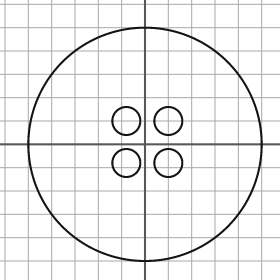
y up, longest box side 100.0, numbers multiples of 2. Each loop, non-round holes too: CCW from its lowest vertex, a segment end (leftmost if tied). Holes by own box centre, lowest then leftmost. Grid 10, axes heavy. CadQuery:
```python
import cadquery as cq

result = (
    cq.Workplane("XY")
    .moveTo(0.0, 0.0)
    .circle(50.0)
    .moveTo(-8.0, -8.0)
    .circle(6.0)
    .moveTo(10.0, -8.0)
    .circle(6.0)
    .moveTo(-8.0, 10.0)
    .circle(6.0)
    .moveTo(10.0, 10.0)
    .circle(6.0)
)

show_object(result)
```